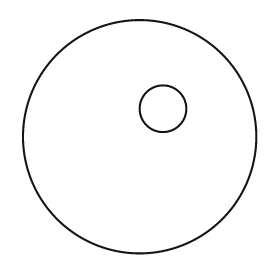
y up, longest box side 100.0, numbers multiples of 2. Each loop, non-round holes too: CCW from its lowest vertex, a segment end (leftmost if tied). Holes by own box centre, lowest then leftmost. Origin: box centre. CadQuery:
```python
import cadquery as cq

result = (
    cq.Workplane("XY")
    .moveTo(0.0, 0.0)
    .circle(50.0)
    .moveTo(10.0, 12.0)
    .circle(10.0)
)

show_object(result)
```